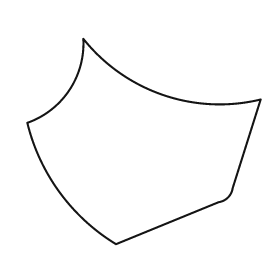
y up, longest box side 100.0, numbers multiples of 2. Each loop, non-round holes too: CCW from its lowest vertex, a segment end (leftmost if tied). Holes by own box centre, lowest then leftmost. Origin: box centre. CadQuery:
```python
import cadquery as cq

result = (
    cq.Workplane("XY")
    .moveTo(-12.0, -44.0)
    .lineTo(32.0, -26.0)
    .threePointArc((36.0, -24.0), (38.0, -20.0))
    .lineTo(50.0, 18.0)
    .threePointArc((8.0, 20.0), (-26.0, 44.0))
    .threePointArc((-32.0, 22.0), (-50.0, 8.0))
    .threePointArc((-36.0, -22.0), (-12.0, -44.0))
    .close()
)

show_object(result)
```